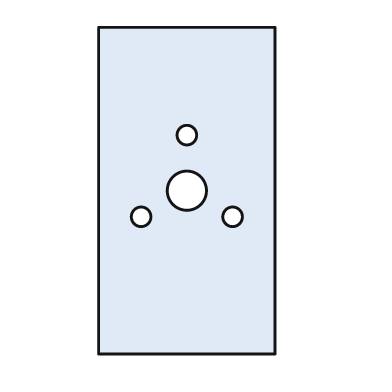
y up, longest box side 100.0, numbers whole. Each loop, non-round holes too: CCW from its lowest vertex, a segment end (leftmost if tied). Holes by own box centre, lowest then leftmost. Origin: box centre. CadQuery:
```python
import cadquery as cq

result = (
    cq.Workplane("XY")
    .moveTo(-27.0, -50.0)
    .lineTo(27.0, -50.0)
    .lineTo(27.0, 50.0)
    .lineTo(-27.0, 50.0)
    .close()
    .moveTo(-14.0, -8.0)
    .circle(3.0)
    .moveTo(14.0, -8.0)
    .circle(3.0)
    .moveTo(0.0, 0.0)
    .circle(6.0)
    .moveTo(0.0, 17.0)
    .circle(3.0)
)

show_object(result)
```